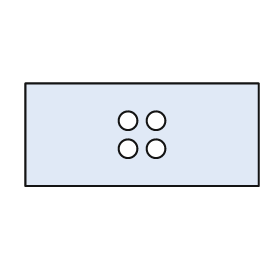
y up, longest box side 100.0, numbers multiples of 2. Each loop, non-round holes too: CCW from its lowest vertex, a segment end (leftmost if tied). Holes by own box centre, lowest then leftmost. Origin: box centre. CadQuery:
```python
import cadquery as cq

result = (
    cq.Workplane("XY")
    .moveTo(-50.0, -22.0)
    .lineTo(50.0, -22.0)
    .lineTo(50.0, 22.0)
    .lineTo(-50.0, 22.0)
    .close()
    .moveTo(-6.0, -6.0)
    .circle(4.0)
    .moveTo(6.0, -6.0)
    .circle(4.0)
    .moveTo(-6.0, 6.0)
    .circle(4.0)
    .moveTo(6.0, 6.0)
    .circle(4.0)
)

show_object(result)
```